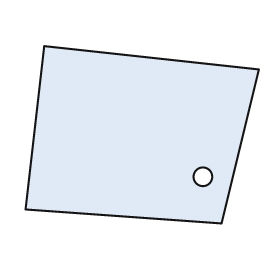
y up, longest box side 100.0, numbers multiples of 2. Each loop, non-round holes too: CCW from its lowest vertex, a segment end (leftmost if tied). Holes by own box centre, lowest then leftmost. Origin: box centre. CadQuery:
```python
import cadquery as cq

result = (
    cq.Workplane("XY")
    .moveTo(34.0, -38.0)
    .lineTo(50.0, 28.0)
    .lineTo(-42.0, 38.0)
    .lineTo(-50.0, -32.0)
    .close()
    .moveTo(26.0, -18.0)
    .circle(4.0)
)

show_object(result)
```